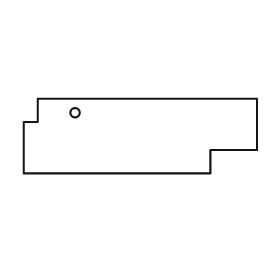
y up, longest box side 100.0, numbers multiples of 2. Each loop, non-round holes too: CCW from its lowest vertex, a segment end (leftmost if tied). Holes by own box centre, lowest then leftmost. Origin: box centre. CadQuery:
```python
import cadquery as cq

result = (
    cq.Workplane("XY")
    .moveTo(-50.0, -16.0)
    .lineTo(30.0, -16.0)
    .lineTo(30.0, -6.0)
    .lineTo(50.0, -6.0)
    .lineTo(50.0, 16.0)
    .lineTo(-44.0, 16.0)
    .lineTo(-44.0, 6.0)
    .lineTo(-50.0, 6.0)
    .close()
    .moveTo(-28.0, 10.0)
    .circle(2.0)
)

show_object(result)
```